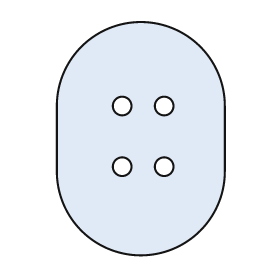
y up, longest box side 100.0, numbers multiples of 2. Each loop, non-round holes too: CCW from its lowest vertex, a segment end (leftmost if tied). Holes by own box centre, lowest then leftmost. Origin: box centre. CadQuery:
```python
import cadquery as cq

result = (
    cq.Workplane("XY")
    .moveTo(-36.0, -14.0)
    .threePointArc((0.0, -50.0), (36.0, -14.0))
    .lineTo(36.0, 14.0)
    .threePointArc((0.0, 50.0), (-36.0, 14.0))
    .close()
    .moveTo(-8.0, -12.0)
    .circle(4.0)
    .moveTo(10.0, -12.0)
    .circle(4.0)
    .moveTo(-8.0, 14.0)
    .circle(4.0)
    .moveTo(10.0, 14.0)
    .circle(4.0)
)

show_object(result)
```